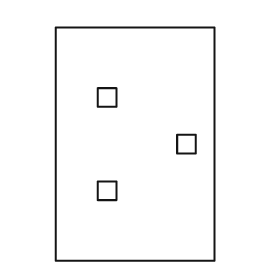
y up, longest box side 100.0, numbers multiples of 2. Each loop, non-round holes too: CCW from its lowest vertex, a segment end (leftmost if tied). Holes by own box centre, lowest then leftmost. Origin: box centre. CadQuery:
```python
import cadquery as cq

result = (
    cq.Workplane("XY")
    .moveTo(-34.0, -50.0)
    .lineTo(34.0, -50.0)
    .lineTo(34.0, 50.0)
    .lineTo(-34.0, 50.0)
    .close()
    .moveTo(-16.0, -24.0)
    .lineTo(-8.0, -24.0)
    .lineTo(-8.0, -16.0)
    .lineTo(-16.0, -16.0)
    .close()
    .moveTo(18.0, -4.0)
    .lineTo(26.0, -4.0)
    .lineTo(26.0, 4.0)
    .lineTo(18.0, 4.0)
    .close()
    .moveTo(-16.0, 16.0)
    .lineTo(-8.0, 16.0)
    .lineTo(-8.0, 24.0)
    .lineTo(-16.0, 24.0)
    .close()
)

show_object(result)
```